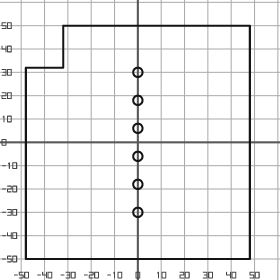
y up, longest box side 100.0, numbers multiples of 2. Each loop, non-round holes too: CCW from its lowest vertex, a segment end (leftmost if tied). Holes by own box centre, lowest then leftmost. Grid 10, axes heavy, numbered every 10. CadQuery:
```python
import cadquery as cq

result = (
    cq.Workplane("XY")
    .moveTo(-48.0, -50.0)
    .lineTo(48.0, -50.0)
    .lineTo(48.0, 50.0)
    .lineTo(-32.0, 50.0)
    .lineTo(-32.0, 32.0)
    .lineTo(-48.0, 32.0)
    .close()
    .moveTo(0.0, -30.0)
    .circle(2.0)
    .moveTo(0.0, -18.0)
    .circle(2.0)
    .moveTo(0.0, -6.0)
    .circle(2.0)
    .moveTo(0.0, 6.0)
    .circle(2.0)
    .moveTo(0.0, 18.0)
    .circle(2.0)
    .moveTo(0.0, 30.0)
    .circle(2.0)
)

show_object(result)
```